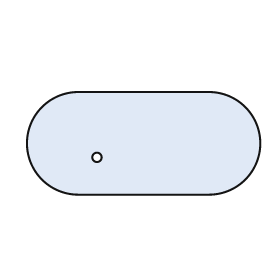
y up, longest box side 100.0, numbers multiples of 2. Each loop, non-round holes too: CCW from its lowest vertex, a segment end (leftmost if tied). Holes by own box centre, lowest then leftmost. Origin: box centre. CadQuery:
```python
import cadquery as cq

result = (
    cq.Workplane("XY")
    .moveTo(-28.0, -22.0)
    .lineTo(28.0, -22.0)
    .threePointArc((50.0, 0.0), (28.0, 22.0))
    .lineTo(-28.0, 22.0)
    .threePointArc((-50.0, 0.0), (-28.0, -22.0))
    .close()
    .moveTo(-20.0, -6.0)
    .circle(2.0)
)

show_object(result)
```